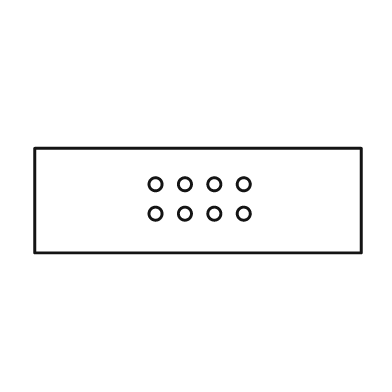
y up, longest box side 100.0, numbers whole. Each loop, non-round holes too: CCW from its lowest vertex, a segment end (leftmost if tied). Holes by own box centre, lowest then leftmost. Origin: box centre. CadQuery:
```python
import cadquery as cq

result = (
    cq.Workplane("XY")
    .moveTo(-50.0, -16.0)
    .lineTo(50.0, -16.0)
    .lineTo(50.0, 16.0)
    .lineTo(-50.0, 16.0)
    .close()
    .moveTo(-13.0, -4.0)
    .circle(2.0)
    .moveTo(-4.0, -4.0)
    .circle(2.0)
    .moveTo(5.0, -4.0)
    .circle(2.0)
    .moveTo(14.0, -4.0)
    .circle(2.0)
    .moveTo(-13.0, 5.0)
    .circle(2.0)
    .moveTo(-4.0, 5.0)
    .circle(2.0)
    .moveTo(5.0, 5.0)
    .circle(2.0)
    .moveTo(14.0, 5.0)
    .circle(2.0)
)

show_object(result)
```